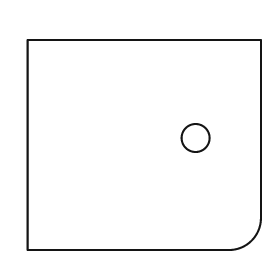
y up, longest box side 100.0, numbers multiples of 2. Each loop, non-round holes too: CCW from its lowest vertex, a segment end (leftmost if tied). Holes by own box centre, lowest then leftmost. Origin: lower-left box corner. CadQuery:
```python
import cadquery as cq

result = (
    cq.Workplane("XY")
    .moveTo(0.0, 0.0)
    .lineTo(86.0, 0.0)
    .threePointArc((96.0, 4.0), (100.0, 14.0))
    .lineTo(100.0, 90.0)
    .lineTo(0.0, 90.0)
    .close()
    .moveTo(72.0, 48.0)
    .circle(6.0)
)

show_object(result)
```